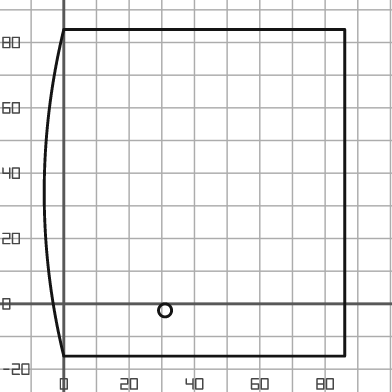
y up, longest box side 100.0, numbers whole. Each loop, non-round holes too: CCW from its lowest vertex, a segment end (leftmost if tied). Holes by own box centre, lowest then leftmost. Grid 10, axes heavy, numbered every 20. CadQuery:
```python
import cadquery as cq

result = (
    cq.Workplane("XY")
    .moveTo(0.0, -16.0)
    .lineTo(86.0, -16.0)
    .lineTo(86.0, 84.0)
    .lineTo(0.0, 84.0)
    .threePointArc((-6.0, 34.0), (0.0, -16.0))
    .close()
    .moveTo(31.0, -2.0)
    .circle(2.0)
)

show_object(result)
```